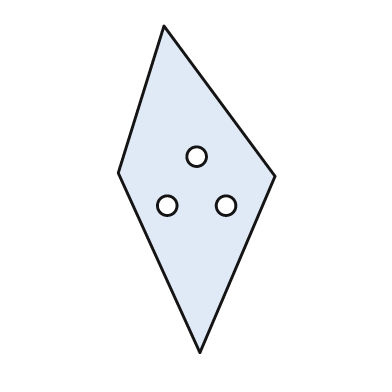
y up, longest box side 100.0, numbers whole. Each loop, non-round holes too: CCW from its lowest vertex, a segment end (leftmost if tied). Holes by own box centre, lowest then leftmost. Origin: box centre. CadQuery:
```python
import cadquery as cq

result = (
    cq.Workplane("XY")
    .moveTo(1.0, -50.0)
    .lineTo(24.0, 4.0)
    .lineTo(-10.0, 50.0)
    .lineTo(-24.0, 5.0)
    .close()
    .moveTo(-9.0, -5.0)
    .circle(3.0)
    .moveTo(9.0, -5.0)
    .circle(3.0)
    .moveTo(0.0, 10.0)
    .circle(3.0)
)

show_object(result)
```